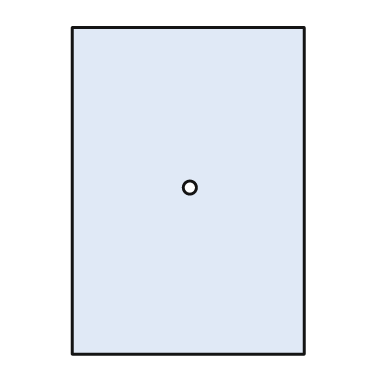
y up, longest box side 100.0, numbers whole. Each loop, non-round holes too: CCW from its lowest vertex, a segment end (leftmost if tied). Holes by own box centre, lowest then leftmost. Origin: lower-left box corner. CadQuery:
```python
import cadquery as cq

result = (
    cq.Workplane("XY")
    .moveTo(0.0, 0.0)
    .lineTo(71.0, 0.0)
    .lineTo(71.0, 100.0)
    .lineTo(0.0, 100.0)
    .close()
    .moveTo(36.0, 51.0)
    .circle(2.0)
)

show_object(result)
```